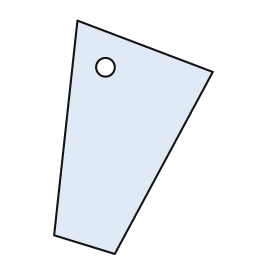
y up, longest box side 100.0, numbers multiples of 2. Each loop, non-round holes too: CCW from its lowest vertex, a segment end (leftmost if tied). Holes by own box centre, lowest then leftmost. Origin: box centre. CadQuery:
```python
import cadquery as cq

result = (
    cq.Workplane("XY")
    .moveTo(-8.0, -50.0)
    .lineTo(34.0, 28.0)
    .lineTo(-24.0, 50.0)
    .lineTo(-34.0, -42.0)
    .close()
    .moveTo(-12.0, 30.0)
    .circle(4.0)
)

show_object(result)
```